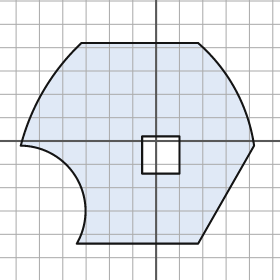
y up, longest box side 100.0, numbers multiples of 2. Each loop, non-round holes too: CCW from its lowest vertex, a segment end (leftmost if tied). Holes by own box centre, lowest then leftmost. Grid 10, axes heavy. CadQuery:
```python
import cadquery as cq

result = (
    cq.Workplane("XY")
    .moveTo(-34.0, -44.0)
    .lineTo(18.0, -44.0)
    .lineTo(42.0, -2.0)
    .threePointArc((34.0, 22.0), (18.0, 42.0))
    .lineTo(-32.0, 42.0)
    .threePointArc((-48.0, 22.0), (-58.0, -2.0))
    .threePointArc((-34.0, -16.0), (-34.0, -44.0))
    .close()
    .moveTo(-6.0, -14.0)
    .lineTo(10.0, -14.0)
    .lineTo(10.0, 2.0)
    .lineTo(-6.0, 2.0)
    .close()
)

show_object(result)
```